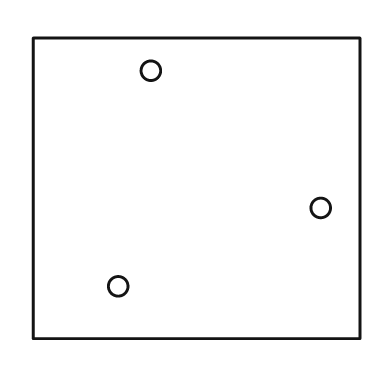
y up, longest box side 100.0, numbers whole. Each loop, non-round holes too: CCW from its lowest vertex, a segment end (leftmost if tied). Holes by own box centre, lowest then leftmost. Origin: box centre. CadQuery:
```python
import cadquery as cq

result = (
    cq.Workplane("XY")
    .moveTo(-50.0, -46.0)
    .lineTo(50.0, -46.0)
    .lineTo(50.0, 46.0)
    .lineTo(-50.0, 46.0)
    .close()
    .moveTo(-24.0, -30.0)
    .circle(3.0)
    .moveTo(38.0, -6.0)
    .circle(3.0)
    .moveTo(-14.0, 36.0)
    .circle(3.0)
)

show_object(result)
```